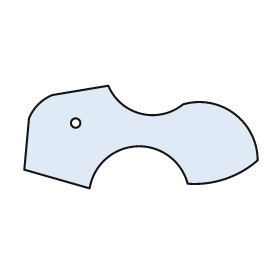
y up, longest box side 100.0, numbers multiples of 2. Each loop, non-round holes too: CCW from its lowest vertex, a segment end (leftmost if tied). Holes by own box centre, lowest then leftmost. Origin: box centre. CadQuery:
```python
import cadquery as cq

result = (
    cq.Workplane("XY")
    .moveTo(-22.0, -22.0)
    .threePointArc((-2.0, -4.0), (20.0, -20.0))
    .threePointArc((36.0, -18.0), (50.0, -10.0))
    .threePointArc((40.0, 10.0), (18.0, 14.0))
    .threePointArc((0.0, 10.0), (-14.0, 22.0))
    .lineTo(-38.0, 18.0)
    .threePointArc((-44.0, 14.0), (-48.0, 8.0))
    .lineTo(-50.0, -14.0)
    .close()
    .moveTo(-28.0, 6.0)
    .circle(2.0)
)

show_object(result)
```